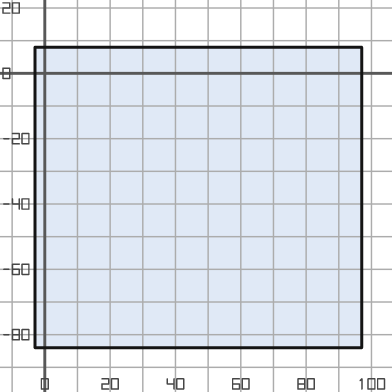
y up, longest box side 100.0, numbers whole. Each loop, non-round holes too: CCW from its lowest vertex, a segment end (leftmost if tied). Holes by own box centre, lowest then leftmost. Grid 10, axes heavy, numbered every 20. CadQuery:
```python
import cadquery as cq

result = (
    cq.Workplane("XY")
    .moveTo(-3.0, -84.0)
    .lineTo(97.0, -84.0)
    .lineTo(97.0, 8.0)
    .lineTo(-3.0, 8.0)
    .close()
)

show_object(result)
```